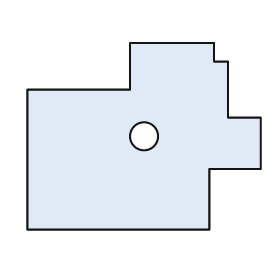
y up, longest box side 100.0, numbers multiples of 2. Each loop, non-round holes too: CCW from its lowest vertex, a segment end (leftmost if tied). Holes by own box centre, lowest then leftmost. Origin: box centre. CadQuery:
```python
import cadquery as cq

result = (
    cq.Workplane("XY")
    .moveTo(-50.0, -40.0)
    .lineTo(28.0, -40.0)
    .lineTo(28.0, -14.0)
    .lineTo(50.0, -14.0)
    .lineTo(50.0, 8.0)
    .lineTo(36.0, 8.0)
    .lineTo(36.0, 32.0)
    .lineTo(30.0, 32.0)
    .lineTo(30.0, 40.0)
    .lineTo(-6.0, 40.0)
    .lineTo(-6.0, 20.0)
    .lineTo(-50.0, 20.0)
    .close()
    .moveTo(0.0, 0.0)
    .circle(6.0)
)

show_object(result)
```